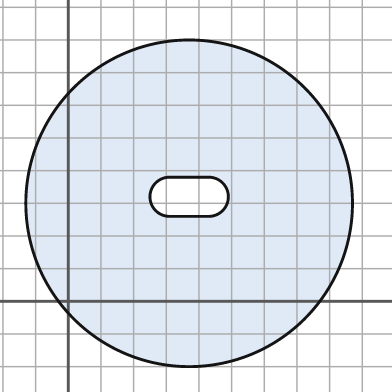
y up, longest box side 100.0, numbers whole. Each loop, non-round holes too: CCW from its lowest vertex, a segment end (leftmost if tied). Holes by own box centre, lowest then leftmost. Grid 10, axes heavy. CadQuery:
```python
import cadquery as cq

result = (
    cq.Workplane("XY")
    .moveTo(37.0, 30.0)
    .circle(50.0)
    .moveTo(31.0, 26.0)
    .lineTo(43.0, 26.0)
    .threePointArc((49.0, 32.0), (43.0, 38.0))
    .lineTo(31.0, 38.0)
    .threePointArc((25.0, 32.0), (31.0, 26.0))
    .close()
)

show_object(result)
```